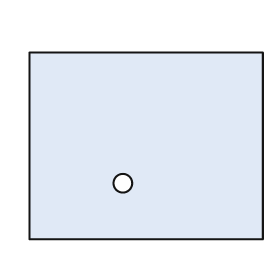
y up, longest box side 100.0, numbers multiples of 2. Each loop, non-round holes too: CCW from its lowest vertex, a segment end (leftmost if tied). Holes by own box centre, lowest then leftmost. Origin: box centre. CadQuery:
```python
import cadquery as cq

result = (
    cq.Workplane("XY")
    .moveTo(-50.0, -40.0)
    .lineTo(50.0, -40.0)
    .lineTo(50.0, 40.0)
    .lineTo(-50.0, 40.0)
    .close()
    .moveTo(-10.0, -16.0)
    .circle(4.0)
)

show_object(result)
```